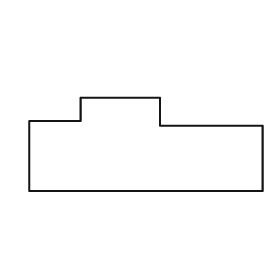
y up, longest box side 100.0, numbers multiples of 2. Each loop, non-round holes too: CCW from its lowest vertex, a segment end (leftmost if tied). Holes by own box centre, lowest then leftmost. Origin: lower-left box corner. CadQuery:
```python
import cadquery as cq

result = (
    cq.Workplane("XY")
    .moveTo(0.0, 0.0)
    .lineTo(100.0, 0.0)
    .lineTo(100.0, 28.0)
    .lineTo(56.0, 28.0)
    .lineTo(56.0, 40.0)
    .lineTo(22.0, 40.0)
    .lineTo(22.0, 30.0)
    .lineTo(0.0, 30.0)
    .close()
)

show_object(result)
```